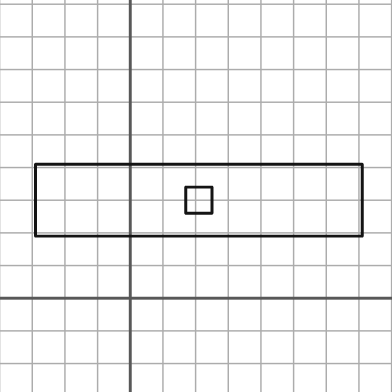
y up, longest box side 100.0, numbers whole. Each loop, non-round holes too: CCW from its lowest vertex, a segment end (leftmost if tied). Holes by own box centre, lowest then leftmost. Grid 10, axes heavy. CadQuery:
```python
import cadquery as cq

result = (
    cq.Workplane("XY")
    .moveTo(-29.0, 19.0)
    .lineTo(71.0, 19.0)
    .lineTo(71.0, 41.0)
    .lineTo(-29.0, 41.0)
    .close()
    .moveTo(17.0, 26.0)
    .lineTo(25.0, 26.0)
    .lineTo(25.0, 34.0)
    .lineTo(17.0, 34.0)
    .close()
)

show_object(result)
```